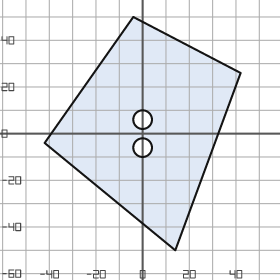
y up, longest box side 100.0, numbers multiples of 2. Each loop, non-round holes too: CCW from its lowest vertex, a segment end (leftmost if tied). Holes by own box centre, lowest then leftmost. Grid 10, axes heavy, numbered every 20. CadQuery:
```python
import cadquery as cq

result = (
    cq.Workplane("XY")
    .moveTo(14.0, -50.0)
    .lineTo(42.0, 26.0)
    .lineTo(-4.0, 50.0)
    .lineTo(-42.0, -4.0)
    .close()
    .moveTo(0.0, -6.0)
    .circle(4.0)
    .moveTo(0.0, 6.0)
    .circle(4.0)
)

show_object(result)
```